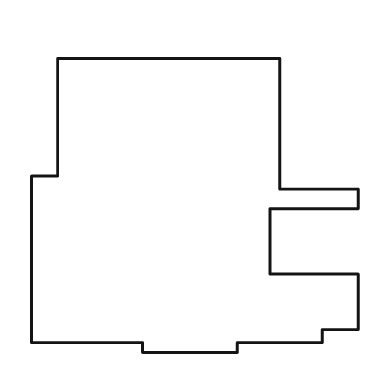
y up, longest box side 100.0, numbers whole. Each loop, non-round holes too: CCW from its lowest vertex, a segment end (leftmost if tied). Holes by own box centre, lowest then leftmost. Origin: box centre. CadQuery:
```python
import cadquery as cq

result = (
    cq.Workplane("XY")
    .moveTo(-16.0, -45.0)
    .lineTo(13.0, -45.0)
    .lineTo(13.0, -42.0)
    .lineTo(39.0, -42.0)
    .lineTo(39.0, -38.0)
    .lineTo(50.0, -38.0)
    .lineTo(50.0, -21.0)
    .lineTo(23.0, -21.0)
    .lineTo(23.0, -1.0)
    .lineTo(50.0, -1.0)
    .lineTo(50.0, 5.0)
    .lineTo(26.0, 5.0)
    .lineTo(26.0, 45.0)
    .lineTo(-42.0, 45.0)
    .lineTo(-42.0, 9.0)
    .lineTo(-50.0, 9.0)
    .lineTo(-50.0, -42.0)
    .lineTo(-16.0, -42.0)
    .close()
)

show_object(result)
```